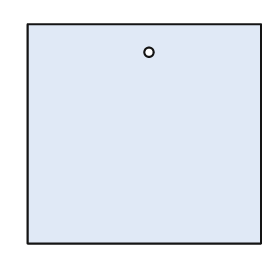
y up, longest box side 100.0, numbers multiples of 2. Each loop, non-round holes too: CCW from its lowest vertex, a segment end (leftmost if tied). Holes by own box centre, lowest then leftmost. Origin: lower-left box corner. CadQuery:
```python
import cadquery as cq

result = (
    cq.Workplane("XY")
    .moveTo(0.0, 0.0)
    .lineTo(100.0, 0.0)
    .lineTo(100.0, 94.0)
    .lineTo(0.0, 94.0)
    .close()
    .moveTo(52.0, 82.0)
    .circle(2.0)
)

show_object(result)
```